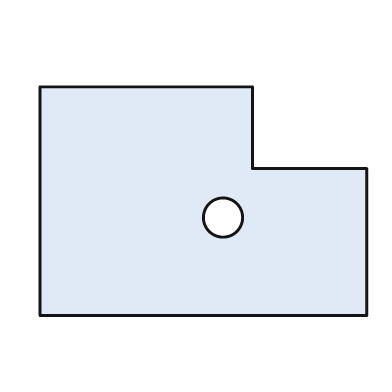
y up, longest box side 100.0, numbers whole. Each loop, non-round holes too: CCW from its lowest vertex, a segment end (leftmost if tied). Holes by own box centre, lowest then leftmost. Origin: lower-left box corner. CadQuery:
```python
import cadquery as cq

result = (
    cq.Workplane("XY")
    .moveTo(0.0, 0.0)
    .lineTo(100.0, 0.0)
    .lineTo(100.0, 45.0)
    .lineTo(65.0, 45.0)
    .lineTo(65.0, 70.0)
    .lineTo(0.0, 70.0)
    .close()
    .moveTo(56.0, 30.0)
    .circle(6.0)
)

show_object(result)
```